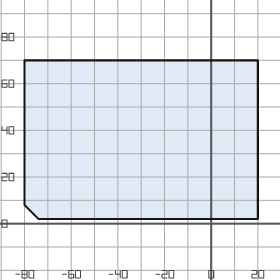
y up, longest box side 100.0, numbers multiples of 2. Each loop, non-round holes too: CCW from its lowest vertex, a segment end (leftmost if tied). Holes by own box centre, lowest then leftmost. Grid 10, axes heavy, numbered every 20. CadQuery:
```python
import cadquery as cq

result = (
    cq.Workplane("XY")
    .moveTo(-74.0, 2.0)
    .lineTo(20.0, 2.0)
    .lineTo(20.0, 70.0)
    .lineTo(-80.0, 70.0)
    .lineTo(-80.0, 8.0)
    .close()
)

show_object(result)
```